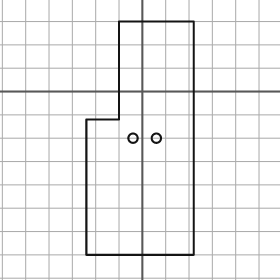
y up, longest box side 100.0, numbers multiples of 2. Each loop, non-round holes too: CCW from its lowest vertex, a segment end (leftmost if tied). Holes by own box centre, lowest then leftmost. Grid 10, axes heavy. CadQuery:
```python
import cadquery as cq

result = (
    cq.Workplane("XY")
    .moveTo(-24.0, -70.0)
    .lineTo(22.0, -70.0)
    .lineTo(22.0, 30.0)
    .lineTo(-10.0, 30.0)
    .lineTo(-10.0, -12.0)
    .lineTo(-24.0, -12.0)
    .close()
    .moveTo(-4.0, -20.0)
    .circle(2.0)
    .moveTo(6.0, -20.0)
    .circle(2.0)
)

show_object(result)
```